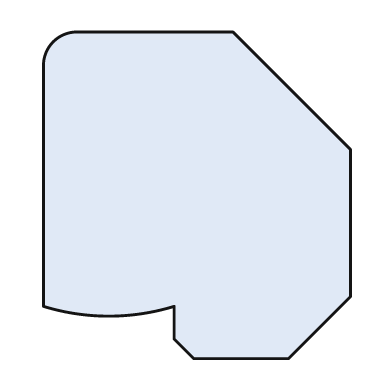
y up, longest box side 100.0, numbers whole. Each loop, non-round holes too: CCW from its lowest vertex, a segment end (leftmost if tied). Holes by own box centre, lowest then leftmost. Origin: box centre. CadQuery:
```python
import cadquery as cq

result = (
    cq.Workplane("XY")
    .moveTo(-1.0, -50.0)
    .lineTo(28.0, -50.0)
    .lineTo(47.0, -31.0)
    .lineTo(47.0, 14.0)
    .lineTo(11.0, 50.0)
    .lineTo(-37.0, 50.0)
    .threePointArc((-44.0, 47.0), (-47.0, 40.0))
    .lineTo(-47.0, -34.0)
    .threePointArc((-27.0, -37.0), (-7.0, -34.0))
    .lineTo(-7.0, -44.0)
    .close()
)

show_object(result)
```